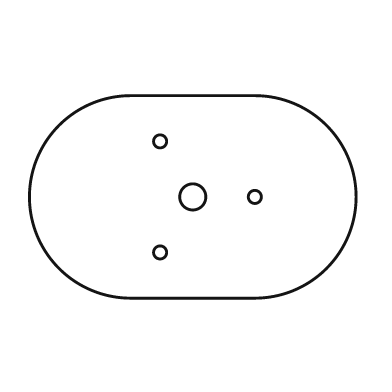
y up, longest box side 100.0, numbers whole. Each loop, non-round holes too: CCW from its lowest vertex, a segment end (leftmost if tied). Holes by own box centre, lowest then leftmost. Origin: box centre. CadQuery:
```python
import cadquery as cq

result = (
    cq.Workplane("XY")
    .moveTo(-19.0, -31.0)
    .lineTo(19.0, -31.0)
    .threePointArc((50.0, 0.0), (19.0, 31.0))
    .lineTo(-19.0, 31.0)
    .threePointArc((-50.0, 0.0), (-19.0, -31.0))
    .close()
    .moveTo(-10.0, -17.0)
    .circle(2.0)
    .moveTo(0.0, 0.0)
    .circle(4.0)
    .moveTo(19.0, 0.0)
    .circle(2.0)
    .moveTo(-10.0, 17.0)
    .circle(2.0)
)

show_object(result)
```